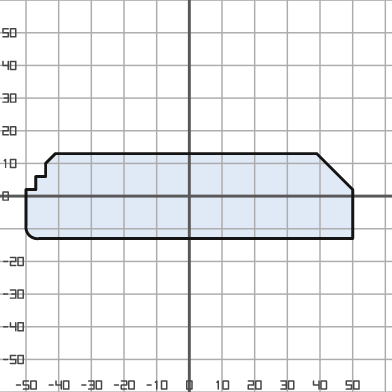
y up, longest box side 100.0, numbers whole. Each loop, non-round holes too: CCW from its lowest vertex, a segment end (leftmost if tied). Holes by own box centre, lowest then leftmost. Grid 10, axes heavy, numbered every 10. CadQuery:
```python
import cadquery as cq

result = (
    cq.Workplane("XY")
    .moveTo(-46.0, -13.0)
    .lineTo(50.0, -13.0)
    .lineTo(50.0, 2.0)
    .lineTo(39.0, 13.0)
    .lineTo(-41.0, 13.0)
    .lineTo(-44.0, 10.0)
    .lineTo(-44.0, 6.0)
    .lineTo(-47.0, 6.0)
    .lineTo(-47.0, 2.0)
    .lineTo(-50.0, 2.0)
    .lineTo(-50.0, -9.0)
    .threePointArc((-49.0, -12.0), (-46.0, -13.0))
    .close()
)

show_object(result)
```